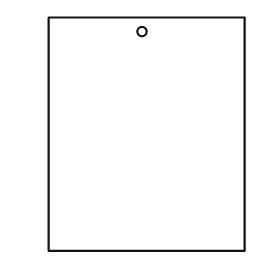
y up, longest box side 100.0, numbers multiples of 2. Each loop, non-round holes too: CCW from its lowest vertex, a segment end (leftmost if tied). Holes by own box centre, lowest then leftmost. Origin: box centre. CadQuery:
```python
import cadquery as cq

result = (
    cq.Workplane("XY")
    .moveTo(-42.0, -50.0)
    .lineTo(42.0, -50.0)
    .lineTo(42.0, 50.0)
    .lineTo(-42.0, 50.0)
    .close()
    .moveTo(-2.0, 44.0)
    .circle(2.0)
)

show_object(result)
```